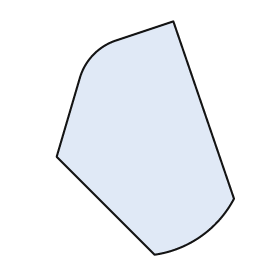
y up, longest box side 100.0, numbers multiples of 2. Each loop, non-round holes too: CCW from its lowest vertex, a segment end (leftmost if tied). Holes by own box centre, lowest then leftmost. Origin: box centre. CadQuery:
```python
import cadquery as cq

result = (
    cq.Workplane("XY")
    .moveTo(4.0, -50.0)
    .threePointArc((24.0, -42.0), (38.0, -26.0))
    .lineTo(12.0, 50.0)
    .lineTo(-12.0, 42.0)
    .threePointArc((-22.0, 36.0), (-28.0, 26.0))
    .lineTo(-38.0, -8.0)
    .close()
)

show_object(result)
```